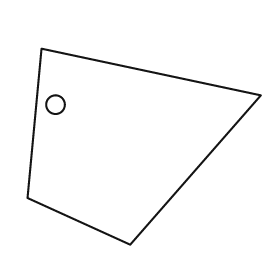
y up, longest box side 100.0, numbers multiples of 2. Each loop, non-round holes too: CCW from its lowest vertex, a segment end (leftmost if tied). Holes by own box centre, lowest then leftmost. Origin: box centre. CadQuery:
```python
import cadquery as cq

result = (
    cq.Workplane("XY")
    .moveTo(-6.0, -42.0)
    .lineTo(50.0, 22.0)
    .lineTo(-44.0, 42.0)
    .lineTo(-50.0, -22.0)
    .close()
    .moveTo(-38.0, 18.0)
    .circle(4.0)
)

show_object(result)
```